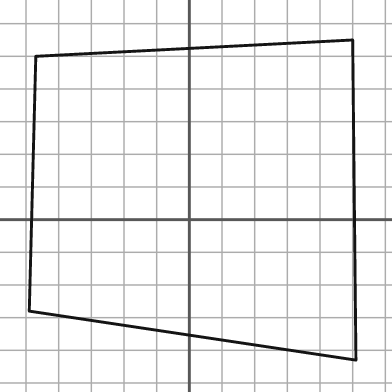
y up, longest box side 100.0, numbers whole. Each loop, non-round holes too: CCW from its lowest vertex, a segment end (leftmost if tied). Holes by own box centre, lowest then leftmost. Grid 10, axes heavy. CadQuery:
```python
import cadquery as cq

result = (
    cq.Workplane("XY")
    .moveTo(51.0, -43.0)
    .lineTo(50.0, 55.0)
    .lineTo(-47.0, 50.0)
    .lineTo(-49.0, -28.0)
    .close()
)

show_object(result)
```